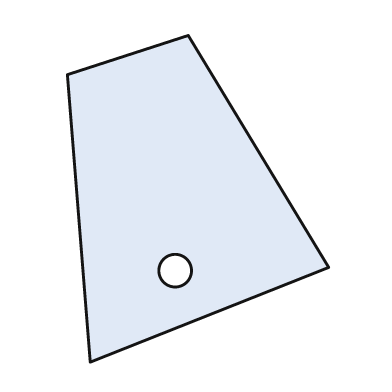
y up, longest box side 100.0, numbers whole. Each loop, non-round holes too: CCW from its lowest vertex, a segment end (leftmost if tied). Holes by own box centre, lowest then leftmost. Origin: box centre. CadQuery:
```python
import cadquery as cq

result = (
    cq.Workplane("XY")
    .moveTo(-33.0, -50.0)
    .lineTo(40.0, -21.0)
    .lineTo(-3.0, 50.0)
    .lineTo(-40.0, 38.0)
    .close()
    .moveTo(-7.0, -22.0)
    .circle(5.0)
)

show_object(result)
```